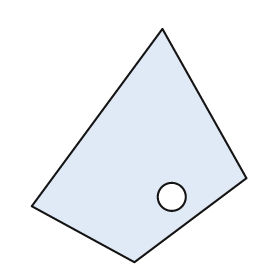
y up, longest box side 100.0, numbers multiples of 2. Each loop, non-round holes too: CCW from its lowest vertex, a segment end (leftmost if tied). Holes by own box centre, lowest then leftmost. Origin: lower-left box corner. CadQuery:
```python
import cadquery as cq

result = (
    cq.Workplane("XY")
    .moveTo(44.0, 0.0)
    .lineTo(92.0, 36.0)
    .lineTo(56.0, 100.0)
    .lineTo(0.0, 24.0)
    .close()
    .moveTo(60.0, 28.0)
    .circle(6.0)
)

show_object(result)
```